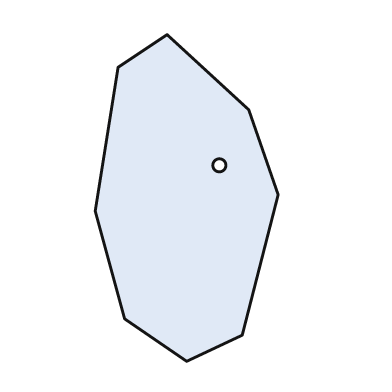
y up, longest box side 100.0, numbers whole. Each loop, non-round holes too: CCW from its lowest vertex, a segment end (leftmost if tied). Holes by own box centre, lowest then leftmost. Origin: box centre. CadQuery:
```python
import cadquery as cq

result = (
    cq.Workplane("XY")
    .moveTo(0.0, -50.0)
    .lineTo(17.0, -42.0)
    .lineTo(28.0, 1.0)
    .lineTo(19.0, 27.0)
    .lineTo(-6.0, 50.0)
    .lineTo(-21.0, 40.0)
    .lineTo(-28.0, -4.0)
    .lineTo(-19.0, -37.0)
    .close()
    .moveTo(10.0, 10.0)
    .circle(2.0)
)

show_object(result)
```